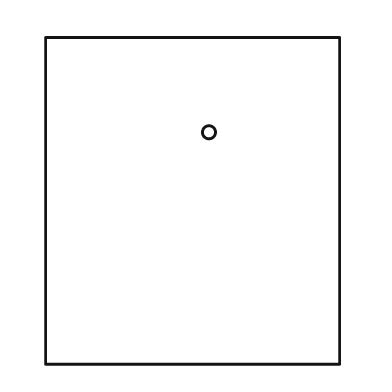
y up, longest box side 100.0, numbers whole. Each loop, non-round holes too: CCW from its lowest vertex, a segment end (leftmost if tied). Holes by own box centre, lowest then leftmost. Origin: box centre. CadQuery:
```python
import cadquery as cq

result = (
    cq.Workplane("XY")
    .moveTo(-45.0, -50.0)
    .lineTo(45.0, -50.0)
    .lineTo(45.0, 50.0)
    .lineTo(-45.0, 50.0)
    .close()
    .moveTo(5.0, 21.0)
    .circle(2.0)
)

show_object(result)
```